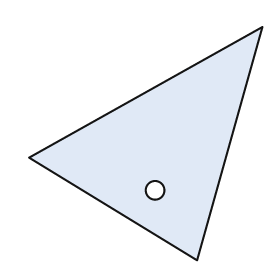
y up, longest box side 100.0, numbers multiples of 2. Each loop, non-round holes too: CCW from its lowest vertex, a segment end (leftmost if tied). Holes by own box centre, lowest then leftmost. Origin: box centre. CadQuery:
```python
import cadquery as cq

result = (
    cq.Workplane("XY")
    .moveTo(22.0, -50.0)
    .lineTo(50.0, 50.0)
    .lineTo(-50.0, -6.0)
    .close()
    .moveTo(4.0, -20.0)
    .circle(4.0)
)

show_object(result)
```